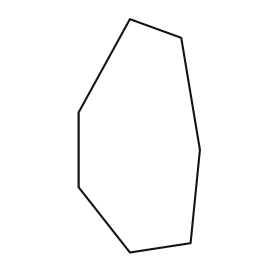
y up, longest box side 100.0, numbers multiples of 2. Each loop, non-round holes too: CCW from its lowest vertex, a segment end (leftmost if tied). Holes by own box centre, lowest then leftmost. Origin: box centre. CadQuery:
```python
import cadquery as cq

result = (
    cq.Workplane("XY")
    .moveTo(-4.0, -50.0)
    .lineTo(22.0, -46.0)
    .lineTo(26.0, -6.0)
    .lineTo(18.0, 42.0)
    .lineTo(-4.0, 50.0)
    .lineTo(-26.0, 10.0)
    .lineTo(-26.0, -22.0)
    .close()
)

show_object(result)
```